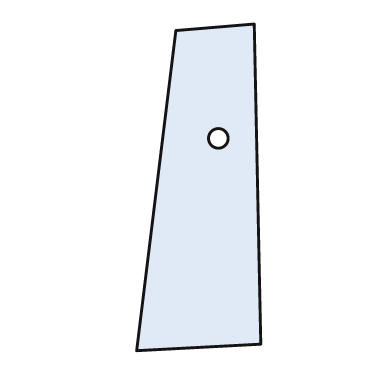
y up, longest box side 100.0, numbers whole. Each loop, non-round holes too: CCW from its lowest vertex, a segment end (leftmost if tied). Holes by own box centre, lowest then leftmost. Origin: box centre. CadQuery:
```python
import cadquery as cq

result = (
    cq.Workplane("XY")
    .moveTo(-19.0, -50.0)
    .lineTo(19.0, -48.0)
    .lineTo(17.0, 50.0)
    .lineTo(-7.0, 48.0)
    .close()
    .moveTo(6.0, 15.0)
    .circle(3.0)
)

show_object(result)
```